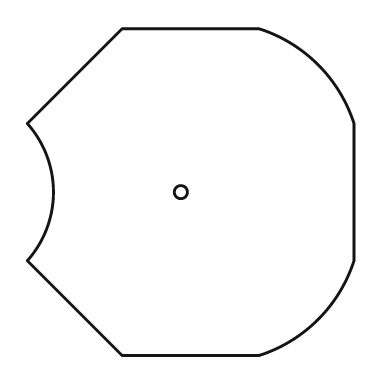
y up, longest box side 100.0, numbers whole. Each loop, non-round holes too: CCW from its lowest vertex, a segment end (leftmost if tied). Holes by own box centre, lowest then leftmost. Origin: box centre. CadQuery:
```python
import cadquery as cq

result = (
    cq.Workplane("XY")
    .moveTo(-21.0, -50.0)
    .lineTo(21.0, -50.0)
    .threePointArc((39.0, -39.0), (50.0, -21.0))
    .lineTo(50.0, 21.0)
    .threePointArc((39.0, 39.0), (21.0, 50.0))
    .lineTo(-21.0, 50.0)
    .lineTo(-50.0, 21.0)
    .threePointArc((-42.0, 0.0), (-50.0, -21.0))
    .close()
    .moveTo(-3.0, 0.0)
    .circle(2.0)
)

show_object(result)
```